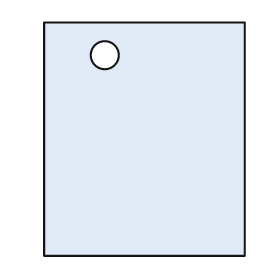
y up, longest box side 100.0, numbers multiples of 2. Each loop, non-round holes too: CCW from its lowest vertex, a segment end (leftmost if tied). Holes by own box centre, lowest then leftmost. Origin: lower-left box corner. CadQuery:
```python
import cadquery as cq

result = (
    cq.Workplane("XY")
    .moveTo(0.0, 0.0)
    .lineTo(86.0, 0.0)
    .lineTo(86.0, 100.0)
    .lineTo(0.0, 100.0)
    .close()
    .moveTo(26.0, 86.0)
    .circle(6.0)
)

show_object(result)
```